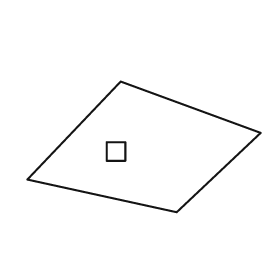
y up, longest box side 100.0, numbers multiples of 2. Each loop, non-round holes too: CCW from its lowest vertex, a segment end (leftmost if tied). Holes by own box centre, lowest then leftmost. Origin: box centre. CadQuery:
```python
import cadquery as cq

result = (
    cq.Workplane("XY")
    .moveTo(14.0, -28.0)
    .lineTo(50.0, 6.0)
    .lineTo(-10.0, 28.0)
    .lineTo(-50.0, -14.0)
    .close()
    .moveTo(-16.0, -6.0)
    .lineTo(-8.0, -6.0)
    .lineTo(-8.0, 2.0)
    .lineTo(-16.0, 2.0)
    .close()
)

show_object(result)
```